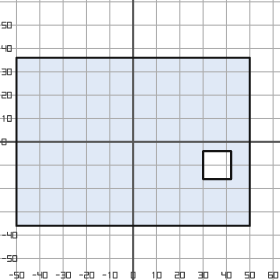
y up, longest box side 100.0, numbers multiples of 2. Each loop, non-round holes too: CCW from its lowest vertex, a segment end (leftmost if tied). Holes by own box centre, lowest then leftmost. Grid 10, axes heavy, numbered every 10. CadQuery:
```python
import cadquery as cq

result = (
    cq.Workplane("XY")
    .moveTo(-50.0, -36.0)
    .lineTo(50.0, -36.0)
    .lineTo(50.0, 36.0)
    .lineTo(-50.0, 36.0)
    .close()
    .moveTo(30.0, -16.0)
    .lineTo(42.0, -16.0)
    .lineTo(42.0, -4.0)
    .lineTo(30.0, -4.0)
    .close()
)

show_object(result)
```